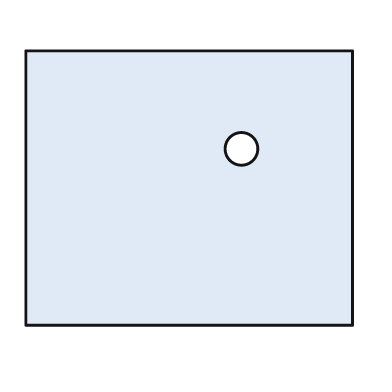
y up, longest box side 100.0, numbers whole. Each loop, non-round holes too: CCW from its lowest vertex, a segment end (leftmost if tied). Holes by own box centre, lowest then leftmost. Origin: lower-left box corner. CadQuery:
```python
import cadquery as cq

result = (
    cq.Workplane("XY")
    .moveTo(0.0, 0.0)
    .lineTo(100.0, 0.0)
    .lineTo(100.0, 84.0)
    .lineTo(0.0, 84.0)
    .close()
    .moveTo(66.0, 54.0)
    .circle(5.0)
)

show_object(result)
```